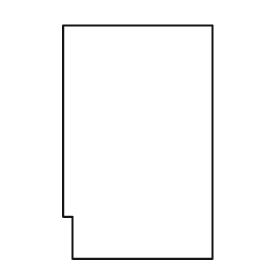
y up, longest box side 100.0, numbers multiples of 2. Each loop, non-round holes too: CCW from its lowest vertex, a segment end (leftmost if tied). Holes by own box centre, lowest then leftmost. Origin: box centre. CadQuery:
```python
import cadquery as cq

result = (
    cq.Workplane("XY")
    .moveTo(-28.0, -50.0)
    .lineTo(32.0, -50.0)
    .lineTo(32.0, 50.0)
    .lineTo(-32.0, 50.0)
    .lineTo(-32.0, -32.0)
    .lineTo(-28.0, -32.0)
    .close()
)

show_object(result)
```